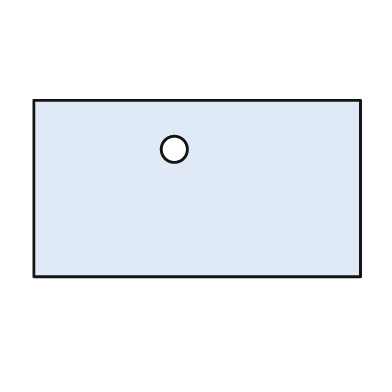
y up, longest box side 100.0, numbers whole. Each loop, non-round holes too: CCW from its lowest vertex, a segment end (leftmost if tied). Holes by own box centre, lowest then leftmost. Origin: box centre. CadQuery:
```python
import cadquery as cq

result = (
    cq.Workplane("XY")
    .moveTo(-50.0, -27.0)
    .lineTo(50.0, -27.0)
    .lineTo(50.0, 27.0)
    .lineTo(-50.0, 27.0)
    .close()
    .moveTo(-7.0, 12.0)
    .circle(4.0)
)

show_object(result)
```